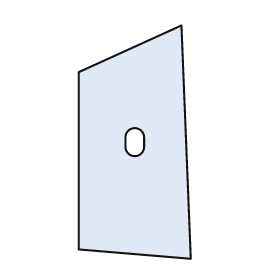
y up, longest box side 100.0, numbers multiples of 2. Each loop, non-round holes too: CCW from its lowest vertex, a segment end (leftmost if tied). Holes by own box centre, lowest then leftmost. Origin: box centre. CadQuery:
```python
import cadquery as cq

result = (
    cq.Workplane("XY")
    .moveTo(24.0, -50.0)
    .lineTo(20.0, 50.0)
    .lineTo(-24.0, 30.0)
    .lineTo(-24.0, -46.0)
    .close()
    .moveTo(-4.0, -2.0)
    .threePointArc((0.0, -6.0), (4.0, -2.0))
    .lineTo(4.0, 2.0)
    .threePointArc((0.0, 6.0), (-4.0, 2.0))
    .close()
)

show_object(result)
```